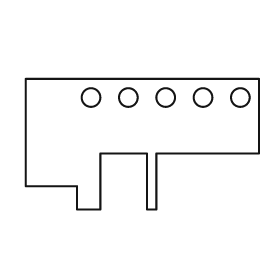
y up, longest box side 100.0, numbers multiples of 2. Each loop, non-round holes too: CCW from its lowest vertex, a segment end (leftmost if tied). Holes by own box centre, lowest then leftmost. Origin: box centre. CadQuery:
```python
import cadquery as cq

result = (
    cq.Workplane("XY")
    .moveTo(-28.0, -28.0)
    .lineTo(-18.0, -28.0)
    .lineTo(-18.0, -4.0)
    .lineTo(2.0, -4.0)
    .lineTo(2.0, -28.0)
    .lineTo(6.0, -28.0)
    .lineTo(6.0, -4.0)
    .lineTo(50.0, -4.0)
    .lineTo(50.0, 28.0)
    .lineTo(-50.0, 28.0)
    .lineTo(-50.0, -18.0)
    .lineTo(-28.0, -18.0)
    .close()
    .moveTo(-22.0, 20.0)
    .circle(4.0)
    .moveTo(-6.0, 20.0)
    .circle(4.0)
    .moveTo(10.0, 20.0)
    .circle(4.0)
    .moveTo(26.0, 20.0)
    .circle(4.0)
    .moveTo(42.0, 20.0)
    .circle(4.0)
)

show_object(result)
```